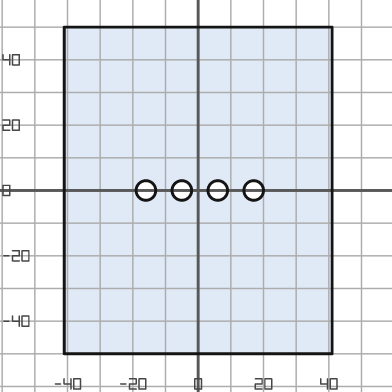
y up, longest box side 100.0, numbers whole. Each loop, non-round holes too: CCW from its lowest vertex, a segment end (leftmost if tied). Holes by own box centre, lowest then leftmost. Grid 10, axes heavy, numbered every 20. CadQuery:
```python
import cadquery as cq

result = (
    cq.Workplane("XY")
    .moveTo(-41.0, -50.0)
    .lineTo(41.0, -50.0)
    .lineTo(41.0, 50.0)
    .lineTo(-41.0, 50.0)
    .close()
    .moveTo(-16.0, 0.0)
    .circle(3.0)
    .moveTo(-5.0, 0.0)
    .circle(3.0)
    .moveTo(6.0, 0.0)
    .circle(3.0)
    .moveTo(17.0, 0.0)
    .circle(3.0)
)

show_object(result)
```